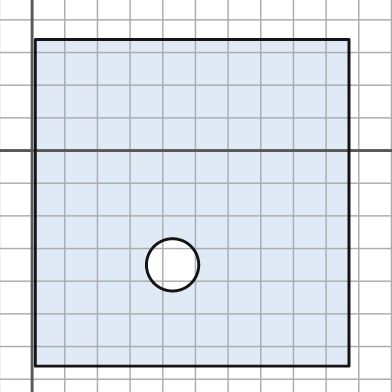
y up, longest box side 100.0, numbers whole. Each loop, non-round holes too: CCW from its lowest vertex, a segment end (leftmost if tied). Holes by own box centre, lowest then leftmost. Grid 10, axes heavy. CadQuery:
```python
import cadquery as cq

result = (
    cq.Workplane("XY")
    .moveTo(1.0, -66.0)
    .lineTo(97.0, -66.0)
    .lineTo(97.0, 34.0)
    .lineTo(1.0, 34.0)
    .close()
    .moveTo(43.0, -35.0)
    .circle(8.0)
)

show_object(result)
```